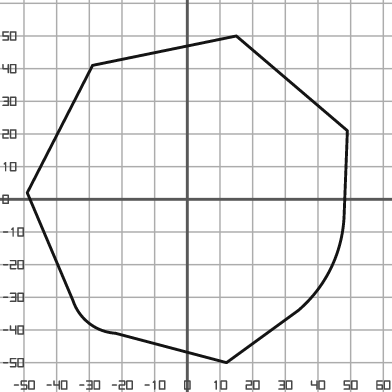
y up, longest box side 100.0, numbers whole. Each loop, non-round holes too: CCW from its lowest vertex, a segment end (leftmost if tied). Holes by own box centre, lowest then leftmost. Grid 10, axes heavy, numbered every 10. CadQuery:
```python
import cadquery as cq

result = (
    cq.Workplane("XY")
    .moveTo(12.0, -50.0)
    .lineTo(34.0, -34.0)
    .threePointArc((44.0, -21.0), (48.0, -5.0))
    .lineTo(49.0, 21.0)
    .lineTo(15.0, 50.0)
    .lineTo(-29.0, 41.0)
    .lineTo(-49.0, 2.0)
    .lineTo(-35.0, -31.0)
    .threePointArc((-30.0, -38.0), (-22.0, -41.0))
    .close()
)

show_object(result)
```